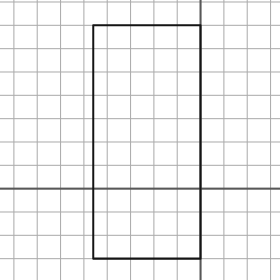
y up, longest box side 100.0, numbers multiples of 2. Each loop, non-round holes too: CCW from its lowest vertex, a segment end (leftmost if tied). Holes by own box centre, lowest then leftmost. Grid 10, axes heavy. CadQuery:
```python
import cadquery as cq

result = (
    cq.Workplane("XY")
    .moveTo(-46.0, -30.0)
    .lineTo(0.0, -30.0)
    .lineTo(0.0, 70.0)
    .lineTo(-46.0, 70.0)
    .close()
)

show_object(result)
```